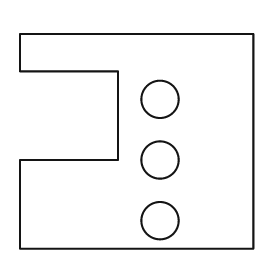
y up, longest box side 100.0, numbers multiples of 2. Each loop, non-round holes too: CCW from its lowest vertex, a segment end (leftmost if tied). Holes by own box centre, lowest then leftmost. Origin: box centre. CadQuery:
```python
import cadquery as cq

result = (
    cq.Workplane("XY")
    .moveTo(-50.0, -46.0)
    .lineTo(50.0, -46.0)
    .lineTo(50.0, 46.0)
    .lineTo(-50.0, 46.0)
    .lineTo(-50.0, 30.0)
    .lineTo(-8.0, 30.0)
    .lineTo(-8.0, -8.0)
    .lineTo(-50.0, -8.0)
    .close()
    .moveTo(10.0, -34.0)
    .circle(8.0)
    .moveTo(10.0, -8.0)
    .circle(8.0)
    .moveTo(10.0, 18.0)
    .circle(8.0)
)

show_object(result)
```